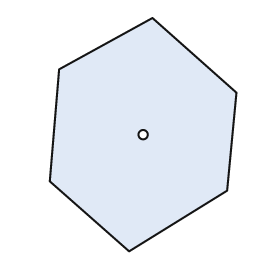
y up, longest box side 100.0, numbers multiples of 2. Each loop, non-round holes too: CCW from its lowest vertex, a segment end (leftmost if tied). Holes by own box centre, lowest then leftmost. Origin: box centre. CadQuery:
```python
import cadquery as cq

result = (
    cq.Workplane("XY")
    .moveTo(-6.0, -50.0)
    .lineTo(36.0, -24.0)
    .lineTo(40.0, 18.0)
    .lineTo(4.0, 50.0)
    .lineTo(-36.0, 28.0)
    .lineTo(-40.0, -20.0)
    .close()
    .moveTo(0.0, 0.0)
    .circle(2.0)
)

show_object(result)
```